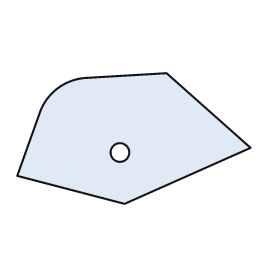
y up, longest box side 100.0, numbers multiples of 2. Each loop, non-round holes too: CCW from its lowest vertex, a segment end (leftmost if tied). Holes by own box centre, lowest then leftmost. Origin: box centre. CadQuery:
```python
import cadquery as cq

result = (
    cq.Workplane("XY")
    .moveTo(-4.0, -28.0)
    .lineTo(50.0, -4.0)
    .lineTo(14.0, 28.0)
    .lineTo(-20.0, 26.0)
    .threePointArc((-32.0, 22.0), (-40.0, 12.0))
    .lineTo(-50.0, -16.0)
    .close()
    .moveTo(-6.0, -6.0)
    .circle(4.0)
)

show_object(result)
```